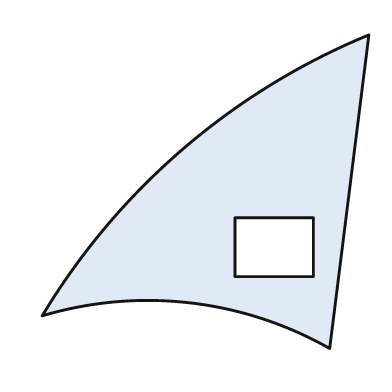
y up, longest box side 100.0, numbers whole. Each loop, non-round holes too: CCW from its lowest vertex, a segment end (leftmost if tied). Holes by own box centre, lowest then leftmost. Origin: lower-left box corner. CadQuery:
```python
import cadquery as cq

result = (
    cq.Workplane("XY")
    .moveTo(88.0, 0.0)
    .lineTo(100.0, 96.0)
    .threePointArc((43.0, 61.0), (0.0, 10.0))
    .threePointArc((45.0, 14.0), (88.0, 0.0))
    .close()
    .moveTo(59.0, 22.0)
    .lineTo(83.0, 22.0)
    .lineTo(83.0, 40.0)
    .lineTo(59.0, 40.0)
    .close()
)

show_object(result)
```